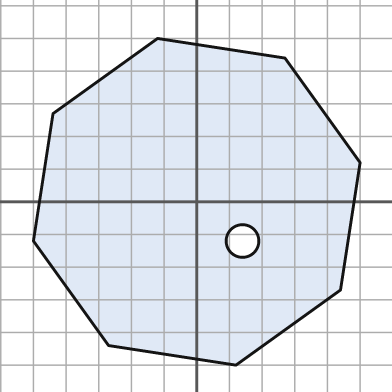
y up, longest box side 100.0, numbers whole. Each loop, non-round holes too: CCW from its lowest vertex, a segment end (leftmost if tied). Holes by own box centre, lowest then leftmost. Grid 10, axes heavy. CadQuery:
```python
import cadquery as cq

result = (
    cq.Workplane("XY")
    .moveTo(12.0, -50.0)
    .lineTo(44.0, -27.0)
    .lineTo(50.0, 12.0)
    .lineTo(27.0, 44.0)
    .lineTo(-12.0, 50.0)
    .lineTo(-44.0, 27.0)
    .lineTo(-50.0, -12.0)
    .lineTo(-27.0, -44.0)
    .close()
    .moveTo(14.0, -12.0)
    .circle(5.0)
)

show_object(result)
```